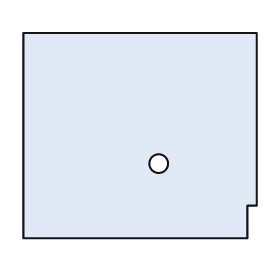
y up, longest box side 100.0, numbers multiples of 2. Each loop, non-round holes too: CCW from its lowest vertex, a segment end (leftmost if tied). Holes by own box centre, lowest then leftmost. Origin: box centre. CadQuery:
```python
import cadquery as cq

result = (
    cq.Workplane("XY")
    .moveTo(-50.0, -44.0)
    .lineTo(46.0, -44.0)
    .lineTo(46.0, -30.0)
    .lineTo(50.0, -30.0)
    .lineTo(50.0, 44.0)
    .lineTo(-50.0, 44.0)
    .close()
    .moveTo(8.0, -12.0)
    .circle(4.0)
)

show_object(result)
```